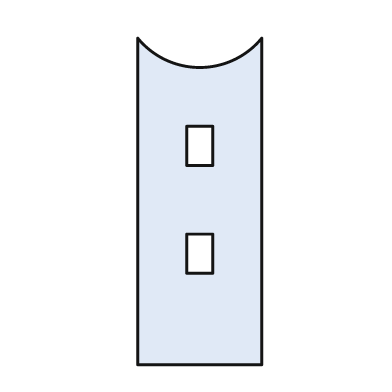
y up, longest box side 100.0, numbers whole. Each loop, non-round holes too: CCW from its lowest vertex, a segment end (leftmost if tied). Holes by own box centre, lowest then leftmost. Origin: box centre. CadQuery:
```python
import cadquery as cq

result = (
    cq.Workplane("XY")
    .moveTo(-19.0, -50.0)
    .lineTo(19.0, -50.0)
    .lineTo(19.0, 50.0)
    .threePointArc((0.0, 41.0), (-19.0, 50.0))
    .close()
    .moveTo(-4.0, -22.0)
    .lineTo(4.0, -22.0)
    .lineTo(4.0, -10.0)
    .lineTo(-4.0, -10.0)
    .close()
    .moveTo(-4.0, 11.0)
    .lineTo(4.0, 11.0)
    .lineTo(4.0, 23.0)
    .lineTo(-4.0, 23.0)
    .close()
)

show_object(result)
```